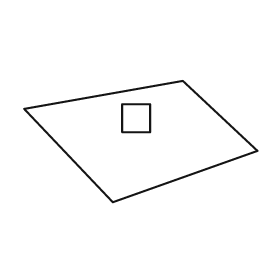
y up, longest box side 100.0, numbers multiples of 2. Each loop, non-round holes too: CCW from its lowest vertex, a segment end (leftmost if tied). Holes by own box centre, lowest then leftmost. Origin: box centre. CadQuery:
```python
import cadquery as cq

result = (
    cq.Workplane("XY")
    .moveTo(-12.0, -26.0)
    .lineTo(50.0, -4.0)
    .lineTo(18.0, 26.0)
    .lineTo(-50.0, 14.0)
    .close()
    .moveTo(-8.0, 4.0)
    .lineTo(4.0, 4.0)
    .lineTo(4.0, 16.0)
    .lineTo(-8.0, 16.0)
    .close()
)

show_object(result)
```